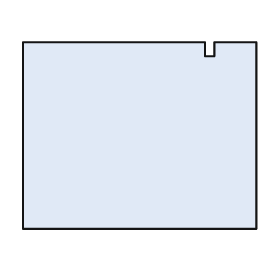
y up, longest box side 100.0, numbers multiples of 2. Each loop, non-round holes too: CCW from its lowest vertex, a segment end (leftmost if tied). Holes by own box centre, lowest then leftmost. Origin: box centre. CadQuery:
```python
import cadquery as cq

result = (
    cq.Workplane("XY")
    .moveTo(-50.0, -40.0)
    .lineTo(50.0, -40.0)
    .lineTo(50.0, 40.0)
    .lineTo(32.0, 40.0)
    .lineTo(32.0, 34.0)
    .lineTo(28.0, 34.0)
    .lineTo(28.0, 40.0)
    .lineTo(-50.0, 40.0)
    .close()
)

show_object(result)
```